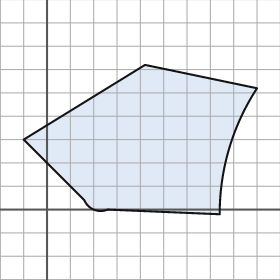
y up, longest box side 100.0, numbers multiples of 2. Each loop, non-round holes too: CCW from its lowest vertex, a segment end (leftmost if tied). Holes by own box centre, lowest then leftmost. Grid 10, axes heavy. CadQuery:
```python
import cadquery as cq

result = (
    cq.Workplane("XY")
    .moveTo(74.0, -2.0)
    .threePointArc((78.0, 26.0), (90.0, 52.0))
    .lineTo(42.0, 62.0)
    .lineTo(-10.0, 30.0)
    .lineTo(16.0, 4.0)
    .threePointArc((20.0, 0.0), (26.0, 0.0))
    .close()
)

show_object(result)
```